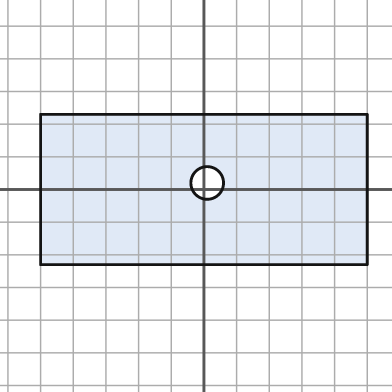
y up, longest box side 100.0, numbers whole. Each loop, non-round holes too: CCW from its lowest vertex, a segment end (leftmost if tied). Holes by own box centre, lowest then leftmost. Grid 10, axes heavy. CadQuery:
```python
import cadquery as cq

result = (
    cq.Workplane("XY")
    .moveTo(-50.0, -23.0)
    .lineTo(50.0, -23.0)
    .lineTo(50.0, 23.0)
    .lineTo(-50.0, 23.0)
    .close()
    .moveTo(1.0, 2.0)
    .circle(5.0)
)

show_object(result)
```